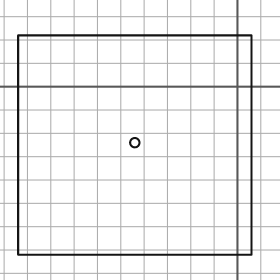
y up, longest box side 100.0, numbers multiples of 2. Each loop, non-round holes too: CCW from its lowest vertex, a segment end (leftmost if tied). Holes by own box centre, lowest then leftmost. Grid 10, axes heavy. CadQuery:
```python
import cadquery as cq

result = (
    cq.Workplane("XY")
    .moveTo(-94.0, -72.0)
    .lineTo(6.0, -72.0)
    .lineTo(6.0, 22.0)
    .lineTo(-94.0, 22.0)
    .close()
    .moveTo(-44.0, -24.0)
    .circle(2.0)
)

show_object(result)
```